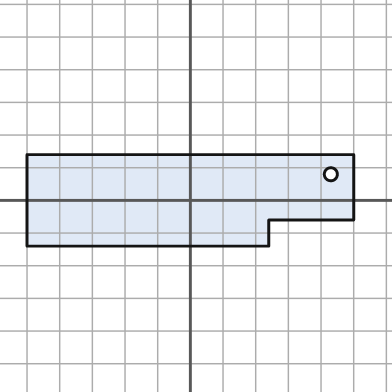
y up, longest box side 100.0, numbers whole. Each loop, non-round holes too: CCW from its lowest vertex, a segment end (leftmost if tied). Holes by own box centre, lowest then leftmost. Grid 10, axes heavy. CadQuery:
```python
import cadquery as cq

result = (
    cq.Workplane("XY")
    .moveTo(-50.0, -14.0)
    .lineTo(24.0, -14.0)
    .lineTo(24.0, -6.0)
    .lineTo(50.0, -6.0)
    .lineTo(50.0, 14.0)
    .lineTo(-50.0, 14.0)
    .close()
    .moveTo(43.0, 8.0)
    .circle(2.0)
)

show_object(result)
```